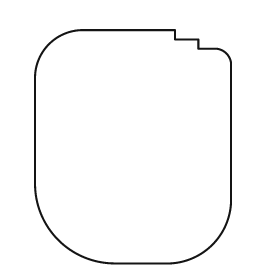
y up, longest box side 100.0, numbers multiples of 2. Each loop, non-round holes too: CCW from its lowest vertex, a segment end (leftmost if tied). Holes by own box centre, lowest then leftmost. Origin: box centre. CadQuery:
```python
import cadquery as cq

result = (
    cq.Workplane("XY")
    .moveTo(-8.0, -50.0)
    .lineTo(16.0, -50.0)
    .threePointArc((34.0, -42.0), (42.0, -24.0))
    .lineTo(42.0, 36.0)
    .threePointArc((40.0, 40.0), (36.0, 42.0))
    .lineTo(28.0, 42.0)
    .lineTo(28.0, 46.0)
    .lineTo(18.0, 46.0)
    .lineTo(18.0, 50.0)
    .lineTo(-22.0, 50.0)
    .threePointArc((-36.0, 44.0), (-42.0, 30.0))
    .lineTo(-42.0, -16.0)
    .threePointArc((-32.0, -40.0), (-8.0, -50.0))
    .close()
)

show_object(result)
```